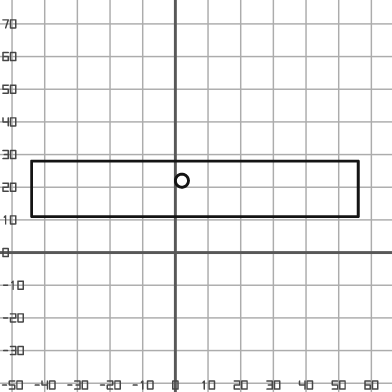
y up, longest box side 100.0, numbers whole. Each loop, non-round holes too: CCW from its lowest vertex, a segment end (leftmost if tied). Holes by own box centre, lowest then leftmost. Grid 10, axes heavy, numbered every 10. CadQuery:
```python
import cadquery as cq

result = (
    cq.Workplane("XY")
    .moveTo(-44.0, 11.0)
    .lineTo(56.0, 11.0)
    .lineTo(56.0, 28.0)
    .lineTo(-44.0, 28.0)
    .close()
    .moveTo(2.0, 22.0)
    .circle(2.0)
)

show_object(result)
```